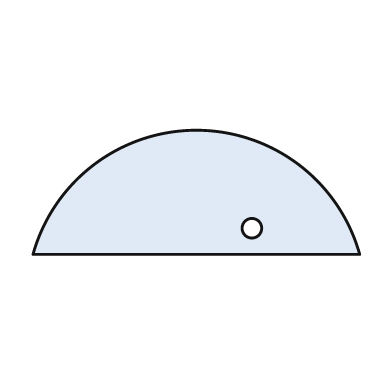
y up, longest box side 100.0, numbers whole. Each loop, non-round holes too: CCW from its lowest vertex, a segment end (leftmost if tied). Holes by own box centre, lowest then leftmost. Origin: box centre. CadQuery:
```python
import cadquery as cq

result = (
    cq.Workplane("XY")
    .moveTo(-50.0, -19.0)
    .lineTo(50.0, -19.0)
    .threePointArc((0.0, 19.0), (-50.0, -19.0))
    .close()
    .moveTo(17.0, -11.0)
    .circle(3.0)
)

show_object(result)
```